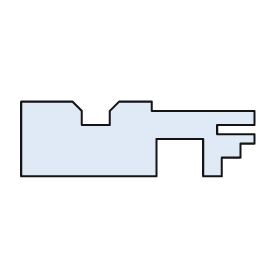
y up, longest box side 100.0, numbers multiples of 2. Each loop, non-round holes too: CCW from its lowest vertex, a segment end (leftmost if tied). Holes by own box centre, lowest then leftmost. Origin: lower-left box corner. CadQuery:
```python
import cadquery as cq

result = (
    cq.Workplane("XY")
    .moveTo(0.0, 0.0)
    .lineTo(58.0, 0.0)
    .lineTo(58.0, 16.0)
    .lineTo(78.0, 16.0)
    .lineTo(78.0, 0.0)
    .lineTo(86.0, 0.0)
    .lineTo(86.0, 8.0)
    .lineTo(94.0, 8.0)
    .lineTo(94.0, 14.0)
    .lineTo(100.0, 14.0)
    .lineTo(100.0, 18.0)
    .lineTo(84.0, 18.0)
    .lineTo(84.0, 22.0)
    .lineTo(100.0, 22.0)
    .lineTo(100.0, 28.0)
    .lineTo(56.0, 28.0)
    .lineTo(56.0, 32.0)
    .lineTo(42.0, 32.0)
    .lineTo(38.0, 28.0)
    .lineTo(38.0, 22.0)
    .lineTo(26.0, 22.0)
    .lineTo(26.0, 28.0)
    .lineTo(22.0, 32.0)
    .lineTo(0.0, 32.0)
    .close()
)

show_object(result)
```